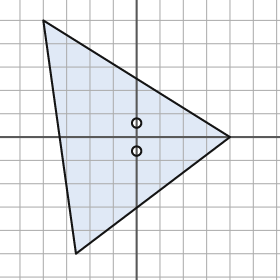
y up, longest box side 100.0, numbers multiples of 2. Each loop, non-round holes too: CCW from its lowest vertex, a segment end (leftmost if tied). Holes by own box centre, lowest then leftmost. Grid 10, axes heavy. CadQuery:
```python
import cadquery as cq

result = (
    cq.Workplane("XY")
    .moveTo(-26.0, -50.0)
    .lineTo(40.0, 0.0)
    .lineTo(-40.0, 50.0)
    .close()
    .moveTo(0.0, -6.0)
    .circle(2.0)
    .moveTo(0.0, 6.0)
    .circle(2.0)
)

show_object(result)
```